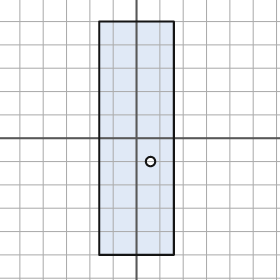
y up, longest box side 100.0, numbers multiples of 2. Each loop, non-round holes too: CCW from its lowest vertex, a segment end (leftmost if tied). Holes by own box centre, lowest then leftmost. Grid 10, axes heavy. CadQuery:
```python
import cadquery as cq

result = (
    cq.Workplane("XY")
    .moveTo(-16.0, -50.0)
    .lineTo(16.0, -50.0)
    .lineTo(16.0, 50.0)
    .lineTo(-16.0, 50.0)
    .close()
    .moveTo(6.0, -10.0)
    .circle(2.0)
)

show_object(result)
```